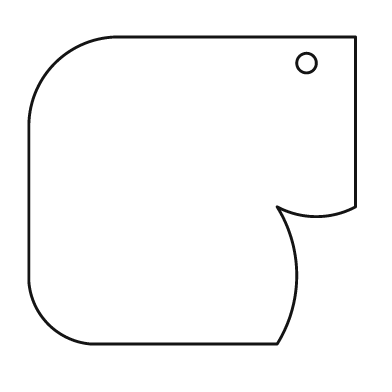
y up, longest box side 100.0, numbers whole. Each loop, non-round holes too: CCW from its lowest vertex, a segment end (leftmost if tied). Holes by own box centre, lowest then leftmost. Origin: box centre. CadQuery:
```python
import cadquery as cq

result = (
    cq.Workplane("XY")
    .moveTo(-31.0, -47.0)
    .lineTo(26.0, -47.0)
    .threePointArc((32.0, -26.0), (26.0, -5.0))
    .threePointArc((38.0, -8.0), (50.0, -5.0))
    .lineTo(50.0, 47.0)
    .lineTo(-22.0, 47.0)
    .threePointArc((-42.0, 39.0), (-50.0, 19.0))
    .lineTo(-50.0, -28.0)
    .threePointArc((-44.0, -41.0), (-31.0, -47.0))
    .close()
    .moveTo(35.0, 39.0)
    .circle(3.0)
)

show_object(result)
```